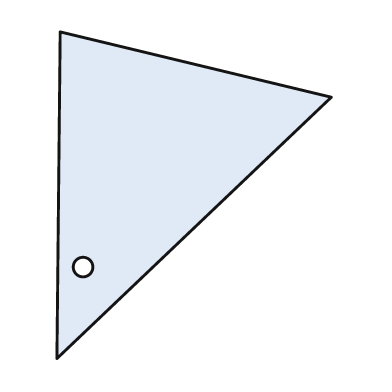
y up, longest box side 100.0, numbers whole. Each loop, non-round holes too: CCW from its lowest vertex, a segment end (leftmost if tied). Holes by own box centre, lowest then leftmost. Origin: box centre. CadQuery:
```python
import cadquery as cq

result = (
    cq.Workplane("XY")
    .moveTo(-42.0, -50.0)
    .lineTo(42.0, 30.0)
    .lineTo(-41.0, 50.0)
    .close()
    .moveTo(-34.0, -22.0)
    .circle(3.0)
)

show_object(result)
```